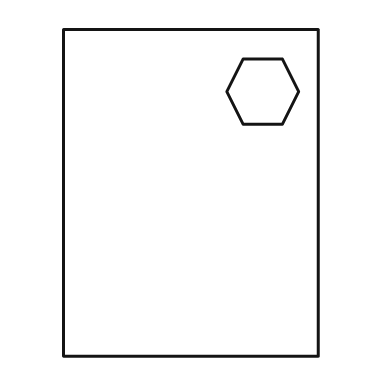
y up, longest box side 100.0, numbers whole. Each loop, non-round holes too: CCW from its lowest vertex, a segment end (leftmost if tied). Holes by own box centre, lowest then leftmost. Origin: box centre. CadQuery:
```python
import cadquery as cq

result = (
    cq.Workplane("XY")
    .moveTo(-39.0, -50.0)
    .lineTo(39.0, -50.0)
    .lineTo(39.0, 50.0)
    .lineTo(-39.0, 50.0)
    .close()
    .moveTo(16.0, 21.0)
    .lineTo(28.0, 21.0)
    .lineTo(33.0, 31.0)
    .lineTo(28.0, 41.0)
    .lineTo(16.0, 41.0)
    .lineTo(11.0, 31.0)
    .close()
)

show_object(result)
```